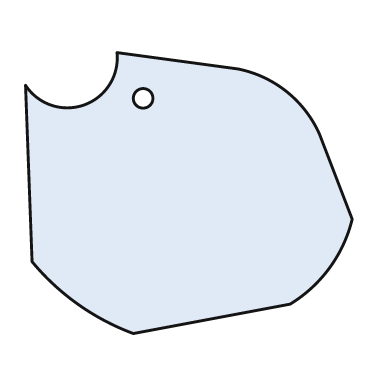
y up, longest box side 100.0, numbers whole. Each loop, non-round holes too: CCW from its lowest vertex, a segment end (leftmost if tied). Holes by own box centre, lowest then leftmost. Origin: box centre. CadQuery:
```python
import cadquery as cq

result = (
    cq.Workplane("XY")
    .moveTo(-17.0, -43.0)
    .lineTo(31.0, -34.0)
    .threePointArc((43.0, -23.0), (50.0, -8.0))
    .lineTo(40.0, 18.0)
    .threePointArc((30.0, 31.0), (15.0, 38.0))
    .lineTo(-22.0, 43.0)
    .threePointArc((-32.0, 27.0), (-50.0, 33.0))
    .lineTo(-48.0, -21.0)
    .threePointArc((-34.0, -34.0), (-17.0, -43.0))
    .close()
    .moveTo(-14.0, 29.0)
    .circle(3.0)
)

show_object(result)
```